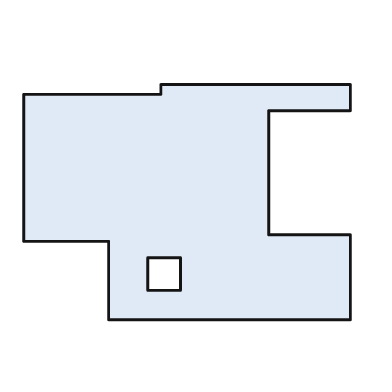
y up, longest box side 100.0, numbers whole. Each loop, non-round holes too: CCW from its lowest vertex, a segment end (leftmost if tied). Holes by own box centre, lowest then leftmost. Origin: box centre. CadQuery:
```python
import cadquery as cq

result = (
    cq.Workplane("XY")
    .moveTo(-24.0, -36.0)
    .lineTo(50.0, -36.0)
    .lineTo(50.0, -10.0)
    .lineTo(25.0, -10.0)
    .lineTo(25.0, 28.0)
    .lineTo(50.0, 28.0)
    .lineTo(50.0, 36.0)
    .lineTo(-8.0, 36.0)
    .lineTo(-8.0, 33.0)
    .lineTo(-50.0, 33.0)
    .lineTo(-50.0, -12.0)
    .lineTo(-24.0, -12.0)
    .close()
    .moveTo(-12.0, -27.0)
    .lineTo(-2.0, -27.0)
    .lineTo(-2.0, -17.0)
    .lineTo(-12.0, -17.0)
    .close()
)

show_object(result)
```